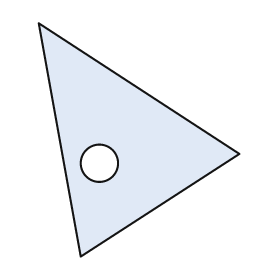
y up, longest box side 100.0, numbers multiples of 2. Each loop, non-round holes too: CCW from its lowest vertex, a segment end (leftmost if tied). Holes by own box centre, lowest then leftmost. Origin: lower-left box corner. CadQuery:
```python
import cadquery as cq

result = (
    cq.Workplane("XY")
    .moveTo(18.0, 0.0)
    .lineTo(86.0, 44.0)
    .lineTo(0.0, 100.0)
    .close()
    .moveTo(26.0, 40.0)
    .circle(8.0)
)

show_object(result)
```